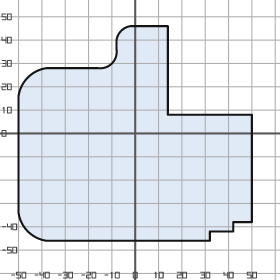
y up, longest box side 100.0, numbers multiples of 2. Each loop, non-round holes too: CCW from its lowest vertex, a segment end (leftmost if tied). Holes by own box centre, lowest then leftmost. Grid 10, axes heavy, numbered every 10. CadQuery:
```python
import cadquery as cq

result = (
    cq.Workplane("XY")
    .moveTo(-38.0, -46.0)
    .lineTo(32.0, -46.0)
    .lineTo(32.0, -42.0)
    .lineTo(42.0, -42.0)
    .lineTo(42.0, -38.0)
    .lineTo(50.0, -38.0)
    .lineTo(50.0, 8.0)
    .lineTo(14.0, 8.0)
    .lineTo(14.0, 46.0)
    .lineTo(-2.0, 46.0)
    .threePointArc((-6.0, 44.0), (-8.0, 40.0))
    .lineTo(-8.0, 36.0)
    .threePointArc((-10.0, 30.0), (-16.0, 28.0))
    .lineTo(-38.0, 28.0)
    .threePointArc((-46.0, 24.0), (-50.0, 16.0))
    .lineTo(-50.0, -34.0)
    .threePointArc((-46.0, -42.0), (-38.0, -46.0))
    .close()
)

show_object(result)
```